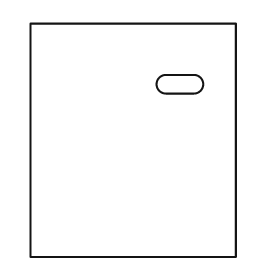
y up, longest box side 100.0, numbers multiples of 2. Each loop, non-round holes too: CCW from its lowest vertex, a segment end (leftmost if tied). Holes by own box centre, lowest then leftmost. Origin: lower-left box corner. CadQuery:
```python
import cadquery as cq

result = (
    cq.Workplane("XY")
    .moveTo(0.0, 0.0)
    .lineTo(88.0, 0.0)
    .lineTo(88.0, 100.0)
    .lineTo(0.0, 100.0)
    .close()
    .moveTo(58.0, 70.0)
    .lineTo(70.0, 70.0)
    .threePointArc((74.0, 74.0), (70.0, 78.0))
    .lineTo(58.0, 78.0)
    .threePointArc((54.0, 74.0), (58.0, 70.0))
    .close()
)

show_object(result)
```